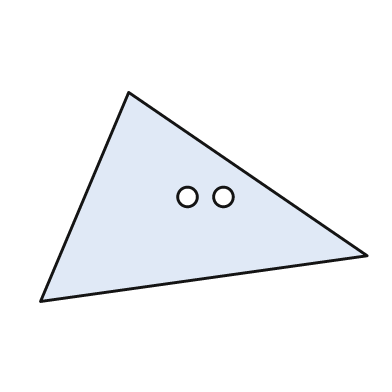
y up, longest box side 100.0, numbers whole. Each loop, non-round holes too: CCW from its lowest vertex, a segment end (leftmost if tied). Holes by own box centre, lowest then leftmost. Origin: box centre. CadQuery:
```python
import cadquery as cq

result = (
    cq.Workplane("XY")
    .moveTo(-50.0, -32.0)
    .lineTo(50.0, -18.0)
    .lineTo(-23.0, 32.0)
    .close()
    .moveTo(-5.0, 0.0)
    .circle(3.0)
    .moveTo(6.0, 0.0)
    .circle(3.0)
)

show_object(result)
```